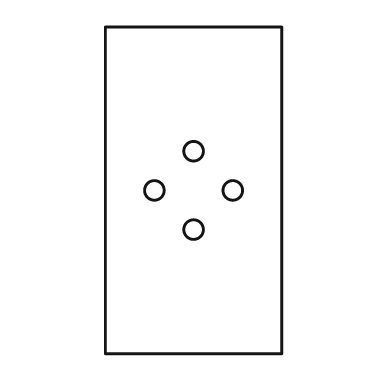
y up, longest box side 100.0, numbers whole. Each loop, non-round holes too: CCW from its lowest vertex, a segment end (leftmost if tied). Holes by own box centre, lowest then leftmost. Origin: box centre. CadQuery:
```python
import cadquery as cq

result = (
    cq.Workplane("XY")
    .moveTo(-27.0, -50.0)
    .lineTo(27.0, -50.0)
    .lineTo(27.0, 50.0)
    .lineTo(-27.0, 50.0)
    .close()
    .moveTo(0.0, -12.0)
    .circle(3.0)
    .moveTo(-12.0, 0.0)
    .circle(3.0)
    .moveTo(12.0, 0.0)
    .circle(3.0)
    .moveTo(0.0, 12.0)
    .circle(3.0)
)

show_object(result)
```